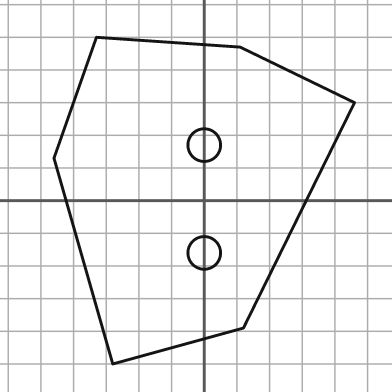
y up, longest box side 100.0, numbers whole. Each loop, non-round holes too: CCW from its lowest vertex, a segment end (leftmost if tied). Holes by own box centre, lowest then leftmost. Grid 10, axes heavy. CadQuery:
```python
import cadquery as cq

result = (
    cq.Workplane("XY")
    .moveTo(-28.0, -50.0)
    .lineTo(12.0, -39.0)
    .lineTo(46.0, 30.0)
    .lineTo(11.0, 47.0)
    .lineTo(-33.0, 50.0)
    .lineTo(-46.0, 13.0)
    .close()
    .moveTo(0.0, -16.0)
    .circle(5.0)
    .moveTo(0.0, 17.0)
    .circle(5.0)
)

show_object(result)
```